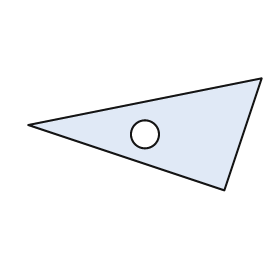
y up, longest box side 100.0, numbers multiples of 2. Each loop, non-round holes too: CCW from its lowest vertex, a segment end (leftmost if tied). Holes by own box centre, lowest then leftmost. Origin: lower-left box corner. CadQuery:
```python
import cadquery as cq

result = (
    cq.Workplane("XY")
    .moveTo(84.0, 0.0)
    .lineTo(100.0, 48.0)
    .lineTo(0.0, 28.0)
    .close()
    .moveTo(50.0, 24.0)
    .circle(6.0)
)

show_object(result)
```